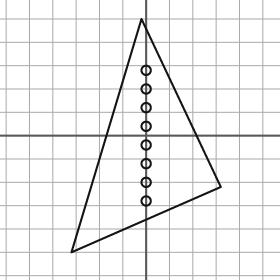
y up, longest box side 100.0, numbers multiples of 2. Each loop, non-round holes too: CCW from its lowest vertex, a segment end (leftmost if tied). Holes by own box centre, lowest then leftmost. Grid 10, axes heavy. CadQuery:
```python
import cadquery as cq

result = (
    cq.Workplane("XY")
    .moveTo(-32.0, -50.0)
    .lineTo(32.0, -22.0)
    .lineTo(-2.0, 50.0)
    .close()
    .moveTo(0.0, -28.0)
    .circle(2.0)
    .moveTo(0.0, -20.0)
    .circle(2.0)
    .moveTo(0.0, -12.0)
    .circle(2.0)
    .moveTo(0.0, -4.0)
    .circle(2.0)
    .moveTo(0.0, 4.0)
    .circle(2.0)
    .moveTo(0.0, 12.0)
    .circle(2.0)
    .moveTo(0.0, 20.0)
    .circle(2.0)
    .moveTo(0.0, 28.0)
    .circle(2.0)
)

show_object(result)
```